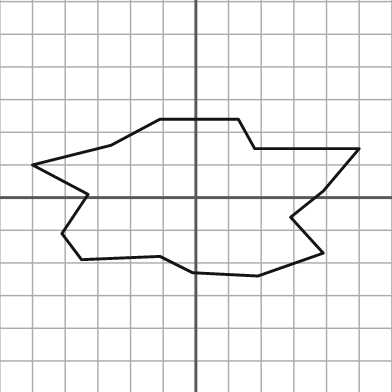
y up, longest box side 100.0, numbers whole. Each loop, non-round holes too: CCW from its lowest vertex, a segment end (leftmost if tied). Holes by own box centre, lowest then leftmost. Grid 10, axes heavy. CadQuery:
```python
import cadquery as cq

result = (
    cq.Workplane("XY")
    .moveTo(19.0, -24.0)
    .lineTo(39.0, -17.0)
    .lineTo(29.0, -6.0)
    .lineTo(39.0, 2.0)
    .lineTo(50.0, 15.0)
    .lineTo(18.0, 15.0)
    .lineTo(13.0, 24.0)
    .lineTo(-11.0, 24.0)
    .lineTo(-26.0, 16.0)
    .lineTo(-50.0, 10.0)
    .lineTo(-33.0, 1.0)
    .lineTo(-41.0, -11.0)
    .lineTo(-35.0, -19.0)
    .lineTo(-11.0, -18.0)
    .lineTo(-1.0, -23.0)
    .close()
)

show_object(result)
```